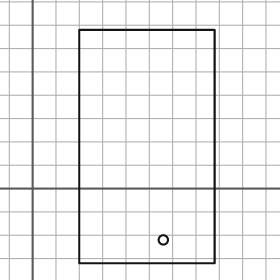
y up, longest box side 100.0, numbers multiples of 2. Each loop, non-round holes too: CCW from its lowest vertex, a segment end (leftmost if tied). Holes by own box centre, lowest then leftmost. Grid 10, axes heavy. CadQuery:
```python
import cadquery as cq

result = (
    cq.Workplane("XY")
    .moveTo(20.0, -32.0)
    .lineTo(78.0, -32.0)
    .lineTo(78.0, 68.0)
    .lineTo(20.0, 68.0)
    .close()
    .moveTo(56.0, -22.0)
    .circle(2.0)
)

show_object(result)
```